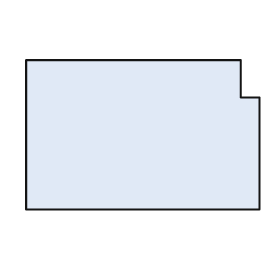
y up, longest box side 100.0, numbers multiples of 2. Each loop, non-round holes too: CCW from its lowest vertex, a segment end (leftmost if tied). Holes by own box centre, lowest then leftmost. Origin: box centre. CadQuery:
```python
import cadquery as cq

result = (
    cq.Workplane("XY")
    .moveTo(-50.0, -32.0)
    .lineTo(50.0, -32.0)
    .lineTo(50.0, 16.0)
    .lineTo(42.0, 16.0)
    .lineTo(42.0, 32.0)
    .lineTo(-50.0, 32.0)
    .close()
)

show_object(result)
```